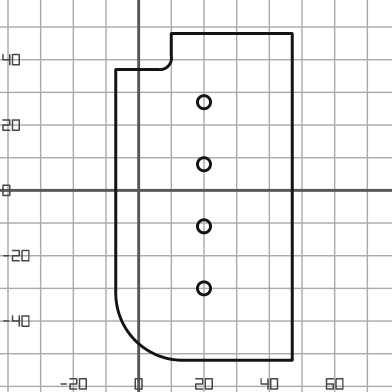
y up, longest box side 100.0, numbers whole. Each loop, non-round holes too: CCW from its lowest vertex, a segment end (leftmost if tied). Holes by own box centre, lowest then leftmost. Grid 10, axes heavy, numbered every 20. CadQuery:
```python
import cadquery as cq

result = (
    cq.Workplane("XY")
    .moveTo(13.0, -52.0)
    .lineTo(47.0, -52.0)
    .lineTo(47.0, 48.0)
    .lineTo(10.0, 48.0)
    .lineTo(10.0, 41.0)
    .threePointArc((9.0, 38.0), (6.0, 37.0))
    .lineTo(-7.0, 37.0)
    .lineTo(-7.0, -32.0)
    .threePointArc((-1.0, -46.0), (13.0, -52.0))
    .close()
    .moveTo(20.0, -30.0)
    .circle(2.0)
    .moveTo(20.0, -11.0)
    .circle(2.0)
    .moveTo(20.0, 8.0)
    .circle(2.0)
    .moveTo(20.0, 27.0)
    .circle(2.0)
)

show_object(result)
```